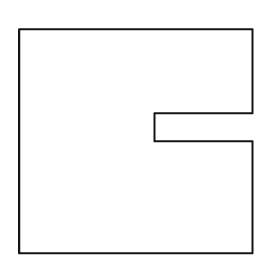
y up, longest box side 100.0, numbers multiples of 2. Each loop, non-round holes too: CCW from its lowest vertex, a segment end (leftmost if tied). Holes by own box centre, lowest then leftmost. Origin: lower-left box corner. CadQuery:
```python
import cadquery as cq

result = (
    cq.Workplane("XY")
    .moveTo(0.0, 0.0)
    .lineTo(100.0, 0.0)
    .lineTo(100.0, 48.0)
    .lineTo(58.0, 48.0)
    .lineTo(58.0, 60.0)
    .lineTo(100.0, 60.0)
    .lineTo(100.0, 96.0)
    .lineTo(0.0, 96.0)
    .close()
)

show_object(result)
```